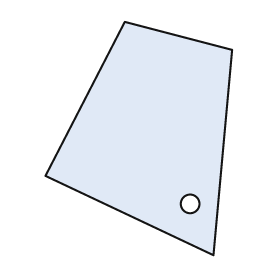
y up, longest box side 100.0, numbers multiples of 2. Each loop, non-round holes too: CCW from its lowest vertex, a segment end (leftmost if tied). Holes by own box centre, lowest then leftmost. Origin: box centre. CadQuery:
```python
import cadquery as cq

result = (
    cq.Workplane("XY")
    .moveTo(32.0, -50.0)
    .lineTo(40.0, 38.0)
    .lineTo(-6.0, 50.0)
    .lineTo(-40.0, -16.0)
    .close()
    .moveTo(22.0, -28.0)
    .circle(4.0)
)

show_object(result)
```